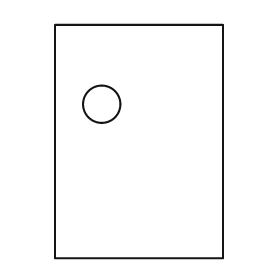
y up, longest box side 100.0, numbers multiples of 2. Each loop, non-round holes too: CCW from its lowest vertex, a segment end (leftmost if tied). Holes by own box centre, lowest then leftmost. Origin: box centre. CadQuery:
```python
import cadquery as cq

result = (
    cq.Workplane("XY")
    .moveTo(-36.0, -50.0)
    .lineTo(36.0, -50.0)
    .lineTo(36.0, 50.0)
    .lineTo(-36.0, 50.0)
    .close()
    .moveTo(-16.0, 16.0)
    .circle(8.0)
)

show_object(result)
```